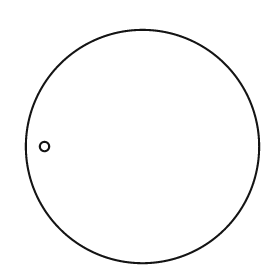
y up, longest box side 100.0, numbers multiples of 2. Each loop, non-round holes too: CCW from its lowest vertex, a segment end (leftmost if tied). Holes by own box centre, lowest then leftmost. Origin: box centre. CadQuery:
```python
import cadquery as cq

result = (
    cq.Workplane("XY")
    .moveTo(0.0, 0.0)
    .circle(50.0)
    .moveTo(-42.0, 0.0)
    .circle(2.0)
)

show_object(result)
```